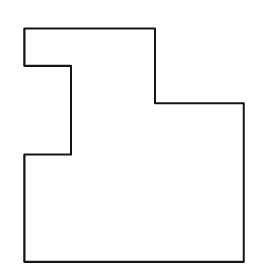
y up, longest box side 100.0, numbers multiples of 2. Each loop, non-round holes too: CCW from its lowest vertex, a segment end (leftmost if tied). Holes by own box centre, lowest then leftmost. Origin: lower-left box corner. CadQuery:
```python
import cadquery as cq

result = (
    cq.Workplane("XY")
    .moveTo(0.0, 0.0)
    .lineTo(94.0, 0.0)
    .lineTo(94.0, 68.0)
    .lineTo(56.0, 68.0)
    .lineTo(56.0, 100.0)
    .lineTo(0.0, 100.0)
    .lineTo(0.0, 84.0)
    .lineTo(20.0, 84.0)
    .lineTo(20.0, 46.0)
    .lineTo(0.0, 46.0)
    .close()
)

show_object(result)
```